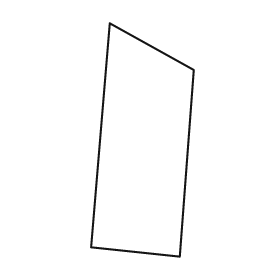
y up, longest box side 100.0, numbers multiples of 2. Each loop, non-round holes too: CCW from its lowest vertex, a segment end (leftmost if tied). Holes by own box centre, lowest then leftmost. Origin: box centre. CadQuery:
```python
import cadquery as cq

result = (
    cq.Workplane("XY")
    .moveTo(16.0, -50.0)
    .lineTo(22.0, 30.0)
    .lineTo(-14.0, 50.0)
    .lineTo(-22.0, -46.0)
    .close()
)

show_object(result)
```